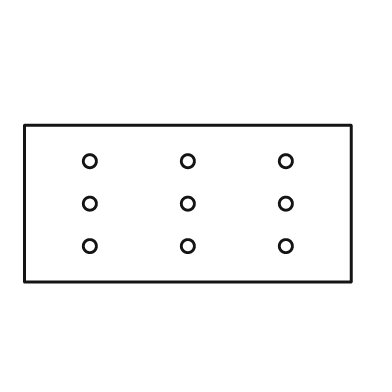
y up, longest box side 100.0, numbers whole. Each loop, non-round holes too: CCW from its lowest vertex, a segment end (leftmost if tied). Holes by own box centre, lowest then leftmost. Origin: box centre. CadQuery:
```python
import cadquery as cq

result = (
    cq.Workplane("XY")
    .moveTo(-50.0, -24.0)
    .lineTo(50.0, -24.0)
    .lineTo(50.0, 24.0)
    .lineTo(-50.0, 24.0)
    .close()
    .moveTo(-30.0, -13.0)
    .circle(2.0)
    .moveTo(0.0, -13.0)
    .circle(2.0)
    .moveTo(30.0, -13.0)
    .circle(2.0)
    .moveTo(-30.0, 0.0)
    .circle(2.0)
    .moveTo(0.0, 0.0)
    .circle(2.0)
    .moveTo(30.0, 0.0)
    .circle(2.0)
    .moveTo(-30.0, 13.0)
    .circle(2.0)
    .moveTo(0.0, 13.0)
    .circle(2.0)
    .moveTo(30.0, 13.0)
    .circle(2.0)
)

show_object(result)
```